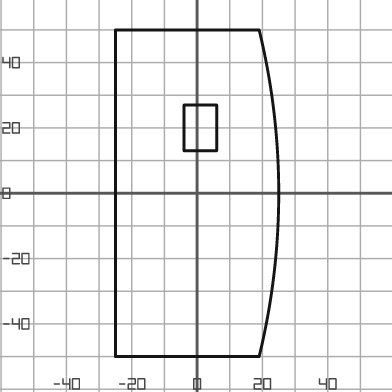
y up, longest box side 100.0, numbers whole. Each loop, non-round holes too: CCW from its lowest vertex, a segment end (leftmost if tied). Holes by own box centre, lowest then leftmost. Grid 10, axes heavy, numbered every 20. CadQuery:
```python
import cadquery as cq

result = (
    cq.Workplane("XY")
    .moveTo(-25.0, -50.0)
    .lineTo(19.0, -50.0)
    .threePointArc((25.0, 0.0), (19.0, 50.0))
    .lineTo(-25.0, 50.0)
    .close()
    .moveTo(-4.0, 13.0)
    .lineTo(6.0, 13.0)
    .lineTo(6.0, 27.0)
    .lineTo(-4.0, 27.0)
    .close()
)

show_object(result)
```